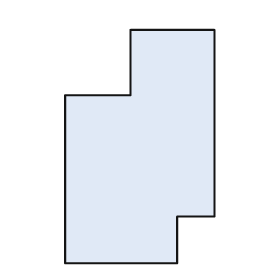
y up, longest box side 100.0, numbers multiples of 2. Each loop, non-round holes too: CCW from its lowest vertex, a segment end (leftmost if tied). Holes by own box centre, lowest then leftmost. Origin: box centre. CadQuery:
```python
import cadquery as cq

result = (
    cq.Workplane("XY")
    .moveTo(-32.0, -50.0)
    .lineTo(16.0, -50.0)
    .lineTo(16.0, -30.0)
    .lineTo(32.0, -30.0)
    .lineTo(32.0, 50.0)
    .lineTo(-4.0, 50.0)
    .lineTo(-4.0, 22.0)
    .lineTo(-32.0, 22.0)
    .close()
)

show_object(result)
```